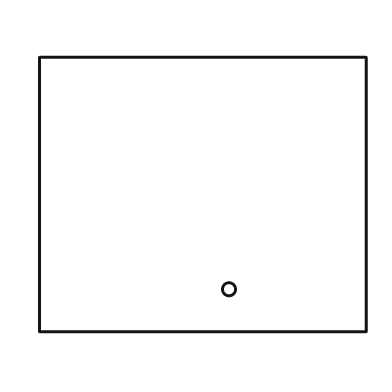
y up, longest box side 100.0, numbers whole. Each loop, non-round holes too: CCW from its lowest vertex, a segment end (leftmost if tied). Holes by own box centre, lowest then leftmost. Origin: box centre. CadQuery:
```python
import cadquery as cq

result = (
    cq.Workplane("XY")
    .moveTo(-50.0, -42.0)
    .lineTo(50.0, -42.0)
    .lineTo(50.0, 42.0)
    .lineTo(-50.0, 42.0)
    .close()
    .moveTo(8.0, -29.0)
    .circle(2.0)
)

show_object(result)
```